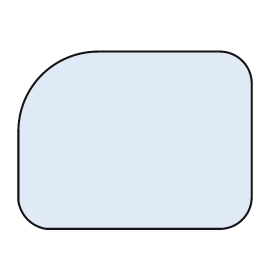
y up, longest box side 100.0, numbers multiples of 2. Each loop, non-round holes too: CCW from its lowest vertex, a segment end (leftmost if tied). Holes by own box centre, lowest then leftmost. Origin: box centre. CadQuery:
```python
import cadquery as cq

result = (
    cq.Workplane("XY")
    .moveTo(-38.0, -38.0)
    .lineTo(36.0, -38.0)
    .threePointArc((46.0, -34.0), (50.0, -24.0))
    .lineTo(50.0, 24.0)
    .threePointArc((46.0, 34.0), (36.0, 38.0))
    .lineTo(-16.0, 38.0)
    .threePointArc((-40.0, 28.0), (-50.0, 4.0))
    .lineTo(-50.0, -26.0)
    .threePointArc((-46.0, -34.0), (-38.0, -38.0))
    .close()
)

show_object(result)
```